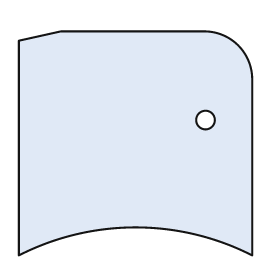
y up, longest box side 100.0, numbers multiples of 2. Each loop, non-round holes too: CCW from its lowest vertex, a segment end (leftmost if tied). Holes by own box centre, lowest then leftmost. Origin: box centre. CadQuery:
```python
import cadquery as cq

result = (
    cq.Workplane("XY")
    .moveTo(-50.0, -48.0)
    .threePointArc((0.0, -36.0), (50.0, -48.0))
    .lineTo(50.0, 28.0)
    .threePointArc((44.0, 42.0), (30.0, 48.0))
    .lineTo(-32.0, 48.0)
    .lineTo(-50.0, 44.0)
    .close()
    .moveTo(30.0, 10.0)
    .circle(4.0)
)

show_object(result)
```